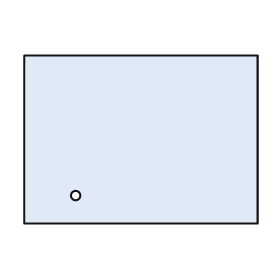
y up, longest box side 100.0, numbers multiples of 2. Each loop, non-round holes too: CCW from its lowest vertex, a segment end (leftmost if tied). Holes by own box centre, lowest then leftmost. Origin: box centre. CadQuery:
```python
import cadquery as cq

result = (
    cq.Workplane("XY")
    .moveTo(-50.0, -36.0)
    .lineTo(50.0, -36.0)
    .lineTo(50.0, 36.0)
    .lineTo(-50.0, 36.0)
    .close()
    .moveTo(-28.0, -24.0)
    .circle(2.0)
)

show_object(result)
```